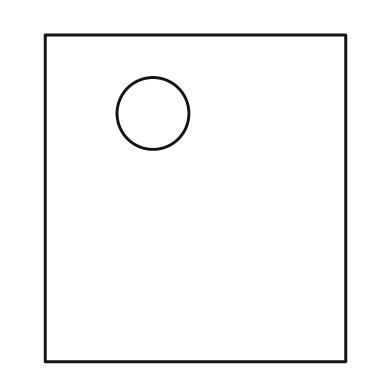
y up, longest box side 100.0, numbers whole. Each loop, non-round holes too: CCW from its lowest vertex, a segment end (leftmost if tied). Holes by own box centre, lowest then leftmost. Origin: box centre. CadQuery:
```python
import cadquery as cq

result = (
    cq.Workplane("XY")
    .moveTo(-46.0, -50.0)
    .lineTo(46.0, -50.0)
    .lineTo(46.0, 50.0)
    .lineTo(-46.0, 50.0)
    .close()
    .moveTo(-13.0, 26.0)
    .circle(11.0)
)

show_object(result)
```